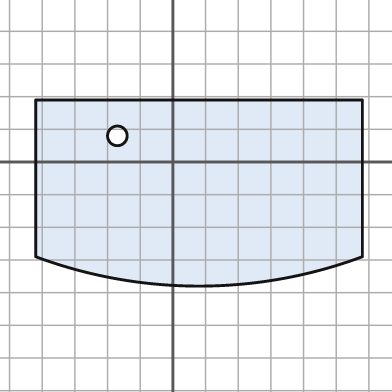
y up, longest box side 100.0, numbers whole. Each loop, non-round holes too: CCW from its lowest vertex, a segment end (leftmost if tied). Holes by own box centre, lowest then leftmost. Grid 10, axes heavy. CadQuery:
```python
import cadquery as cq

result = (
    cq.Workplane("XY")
    .moveTo(-42.0, -29.0)
    .threePointArc((8.0, -38.0), (58.0, -29.0))
    .lineTo(58.0, 19.0)
    .lineTo(-42.0, 19.0)
    .close()
    .moveTo(-17.0, 8.0)
    .circle(3.0)
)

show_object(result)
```